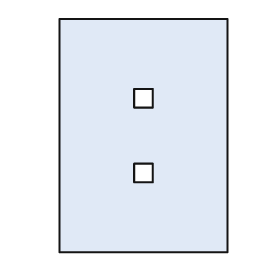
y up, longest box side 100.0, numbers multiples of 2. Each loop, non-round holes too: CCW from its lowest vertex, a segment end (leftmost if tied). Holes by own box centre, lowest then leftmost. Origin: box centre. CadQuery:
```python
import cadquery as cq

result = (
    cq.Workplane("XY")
    .moveTo(-36.0, -50.0)
    .lineTo(36.0, -50.0)
    .lineTo(36.0, 50.0)
    .lineTo(-36.0, 50.0)
    .close()
    .moveTo(-4.0, -20.0)
    .lineTo(4.0, -20.0)
    .lineTo(4.0, -12.0)
    .lineTo(-4.0, -12.0)
    .close()
    .moveTo(-4.0, 12.0)
    .lineTo(4.0, 12.0)
    .lineTo(4.0, 20.0)
    .lineTo(-4.0, 20.0)
    .close()
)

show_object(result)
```